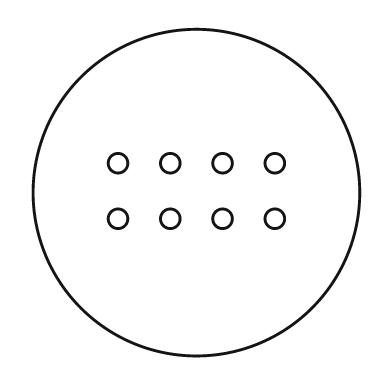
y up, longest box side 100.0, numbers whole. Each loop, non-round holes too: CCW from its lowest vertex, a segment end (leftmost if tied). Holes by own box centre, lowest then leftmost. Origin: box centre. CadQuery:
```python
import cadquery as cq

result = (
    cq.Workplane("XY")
    .moveTo(0.0, 0.0)
    .circle(50.0)
    .moveTo(-24.0, -8.0)
    .circle(3.0)
    .moveTo(-8.0, -8.0)
    .circle(3.0)
    .moveTo(8.0, -8.0)
    .circle(3.0)
    .moveTo(24.0, -8.0)
    .circle(3.0)
    .moveTo(-24.0, 9.0)
    .circle(3.0)
    .moveTo(-8.0, 9.0)
    .circle(3.0)
    .moveTo(8.0, 9.0)
    .circle(3.0)
    .moveTo(24.0, 9.0)
    .circle(3.0)
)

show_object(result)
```